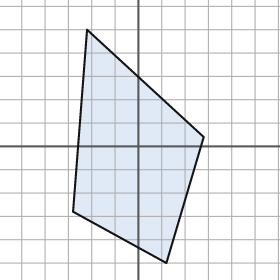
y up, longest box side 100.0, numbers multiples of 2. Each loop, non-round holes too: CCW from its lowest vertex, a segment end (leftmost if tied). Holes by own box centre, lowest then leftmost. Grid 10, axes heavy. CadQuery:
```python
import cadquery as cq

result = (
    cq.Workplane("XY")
    .moveTo(12.0, -50.0)
    .lineTo(28.0, 4.0)
    .lineTo(-22.0, 50.0)
    .lineTo(-28.0, -28.0)
    .close()
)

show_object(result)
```